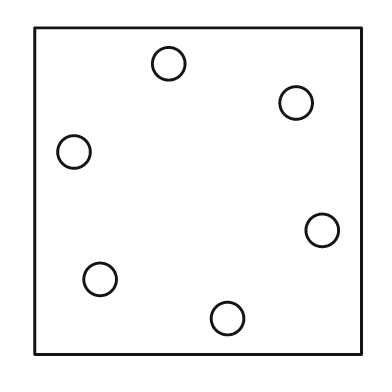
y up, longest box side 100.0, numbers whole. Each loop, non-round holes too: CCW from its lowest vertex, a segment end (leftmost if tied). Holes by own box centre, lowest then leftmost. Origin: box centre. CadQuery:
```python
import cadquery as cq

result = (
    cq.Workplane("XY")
    .moveTo(-50.0, -50.0)
    .lineTo(50.0, -50.0)
    .lineTo(50.0, 50.0)
    .lineTo(-50.0, 50.0)
    .close()
    .moveTo(9.0, -39.0)
    .circle(5.0)
    .moveTo(-30.0, -27.0)
    .circle(5.0)
    .moveTo(38.0, -12.0)
    .circle(5.0)
    .moveTo(-38.0, 12.0)
    .circle(5.0)
    .moveTo(30.0, 27.0)
    .circle(5.0)
    .moveTo(-9.0, 39.0)
    .circle(5.0)
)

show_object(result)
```